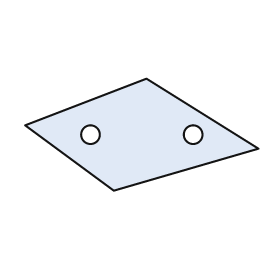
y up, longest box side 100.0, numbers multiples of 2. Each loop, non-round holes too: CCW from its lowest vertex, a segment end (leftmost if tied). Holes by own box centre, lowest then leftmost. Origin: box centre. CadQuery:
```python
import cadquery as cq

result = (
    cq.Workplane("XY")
    .moveTo(-12.0, -24.0)
    .lineTo(50.0, -6.0)
    .lineTo(2.0, 24.0)
    .lineTo(-50.0, 4.0)
    .close()
    .moveTo(-22.0, 0.0)
    .circle(4.0)
    .moveTo(22.0, 0.0)
    .circle(4.0)
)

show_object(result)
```